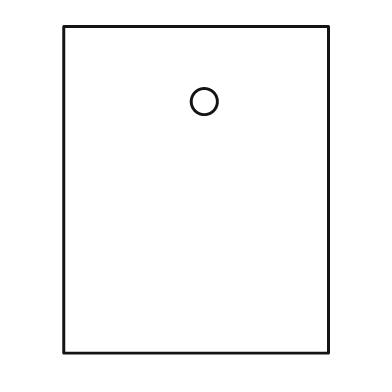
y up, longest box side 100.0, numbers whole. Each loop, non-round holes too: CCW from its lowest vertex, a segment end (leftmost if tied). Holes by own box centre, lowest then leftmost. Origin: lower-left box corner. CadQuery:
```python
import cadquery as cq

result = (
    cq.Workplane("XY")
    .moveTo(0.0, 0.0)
    .lineTo(81.0, 0.0)
    .lineTo(81.0, 100.0)
    .lineTo(0.0, 100.0)
    .close()
    .moveTo(43.0, 77.0)
    .circle(4.0)
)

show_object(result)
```